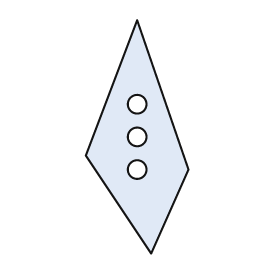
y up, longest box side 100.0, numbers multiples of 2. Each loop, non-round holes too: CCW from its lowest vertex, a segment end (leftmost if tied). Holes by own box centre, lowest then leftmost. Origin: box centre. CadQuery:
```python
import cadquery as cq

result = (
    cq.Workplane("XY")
    .moveTo(6.0, -50.0)
    .lineTo(22.0, -14.0)
    .lineTo(0.0, 50.0)
    .lineTo(-22.0, -8.0)
    .close()
    .moveTo(0.0, -14.0)
    .circle(4.0)
    .moveTo(0.0, 0.0)
    .circle(4.0)
    .moveTo(0.0, 14.0)
    .circle(4.0)
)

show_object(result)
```